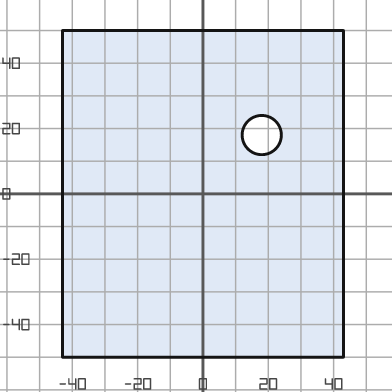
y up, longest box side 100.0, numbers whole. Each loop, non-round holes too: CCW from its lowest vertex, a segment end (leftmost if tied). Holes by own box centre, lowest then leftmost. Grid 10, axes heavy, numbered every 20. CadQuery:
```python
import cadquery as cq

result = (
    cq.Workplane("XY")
    .moveTo(-43.0, -50.0)
    .lineTo(43.0, -50.0)
    .lineTo(43.0, 50.0)
    .lineTo(-43.0, 50.0)
    .close()
    .moveTo(18.0, 18.0)
    .circle(6.0)
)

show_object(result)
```